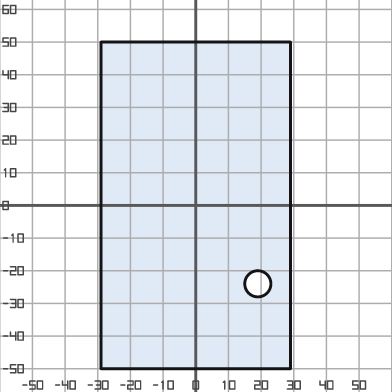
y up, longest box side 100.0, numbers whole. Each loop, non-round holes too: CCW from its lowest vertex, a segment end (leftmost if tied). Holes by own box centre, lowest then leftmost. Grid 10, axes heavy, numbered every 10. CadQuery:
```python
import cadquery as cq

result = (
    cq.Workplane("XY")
    .moveTo(-29.0, -50.0)
    .lineTo(29.0, -50.0)
    .lineTo(29.0, 50.0)
    .lineTo(-29.0, 50.0)
    .close()
    .moveTo(19.0, -24.0)
    .circle(4.0)
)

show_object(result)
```